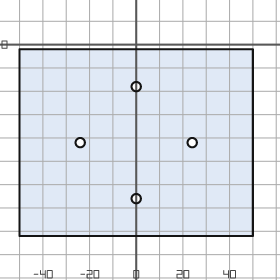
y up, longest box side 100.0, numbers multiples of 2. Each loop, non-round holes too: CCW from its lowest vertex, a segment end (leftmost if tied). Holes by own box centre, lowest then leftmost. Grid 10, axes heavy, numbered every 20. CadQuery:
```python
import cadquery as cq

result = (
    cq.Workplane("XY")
    .moveTo(-50.0, -82.0)
    .lineTo(50.0, -82.0)
    .lineTo(50.0, -2.0)
    .lineTo(-50.0, -2.0)
    .close()
    .moveTo(0.0, -66.0)
    .circle(2.0)
    .moveTo(-24.0, -42.0)
    .circle(2.0)
    .moveTo(24.0, -42.0)
    .circle(2.0)
    .moveTo(0.0, -18.0)
    .circle(2.0)
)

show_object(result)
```